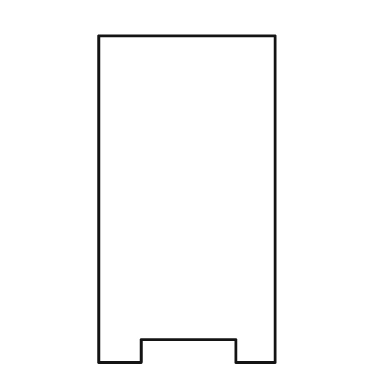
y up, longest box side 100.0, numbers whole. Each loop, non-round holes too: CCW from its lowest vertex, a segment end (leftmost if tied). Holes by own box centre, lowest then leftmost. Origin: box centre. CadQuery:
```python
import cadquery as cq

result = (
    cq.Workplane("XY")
    .moveTo(-27.0, -50.0)
    .lineTo(-14.0, -50.0)
    .lineTo(-14.0, -43.0)
    .lineTo(15.0, -43.0)
    .lineTo(15.0, -50.0)
    .lineTo(27.0, -50.0)
    .lineTo(27.0, 50.0)
    .lineTo(-27.0, 50.0)
    .close()
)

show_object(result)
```